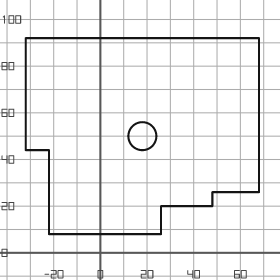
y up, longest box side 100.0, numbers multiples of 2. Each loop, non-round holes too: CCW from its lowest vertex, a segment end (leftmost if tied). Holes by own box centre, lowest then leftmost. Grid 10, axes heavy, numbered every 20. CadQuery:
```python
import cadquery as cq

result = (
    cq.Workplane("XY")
    .moveTo(-22.0, 8.0)
    .lineTo(26.0, 8.0)
    .lineTo(26.0, 20.0)
    .lineTo(48.0, 20.0)
    .lineTo(48.0, 26.0)
    .lineTo(68.0, 26.0)
    .lineTo(68.0, 92.0)
    .lineTo(-32.0, 92.0)
    .lineTo(-32.0, 44.0)
    .lineTo(-22.0, 44.0)
    .close()
    .moveTo(18.0, 50.0)
    .circle(6.0)
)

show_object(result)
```